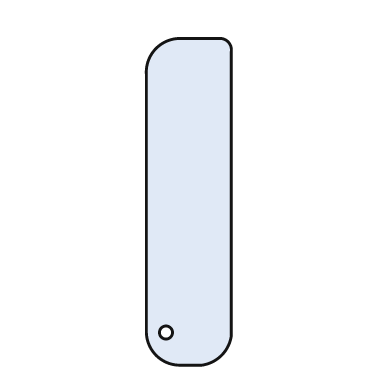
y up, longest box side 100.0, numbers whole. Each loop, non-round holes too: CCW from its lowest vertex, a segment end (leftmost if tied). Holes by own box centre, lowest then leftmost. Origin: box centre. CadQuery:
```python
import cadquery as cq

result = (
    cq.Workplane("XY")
    .moveTo(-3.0, -50.0)
    .lineTo(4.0, -50.0)
    .threePointArc((10.0, -47.0), (13.0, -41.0))
    .lineTo(13.0, 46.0)
    .threePointArc((12.0, 49.0), (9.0, 50.0))
    .lineTo(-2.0, 50.0)
    .threePointArc((-10.0, 47.0), (-13.0, 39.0))
    .lineTo(-13.0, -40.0)
    .threePointArc((-10.0, -47.0), (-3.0, -50.0))
    .close()
    .moveTo(-7.0, -40.0)
    .circle(2.0)
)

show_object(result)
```